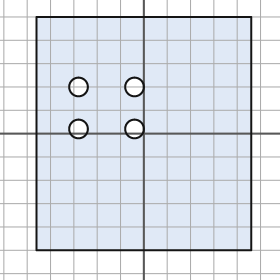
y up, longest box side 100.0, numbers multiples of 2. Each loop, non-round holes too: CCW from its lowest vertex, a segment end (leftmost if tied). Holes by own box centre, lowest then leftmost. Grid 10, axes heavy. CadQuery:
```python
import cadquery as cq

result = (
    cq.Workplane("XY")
    .moveTo(-46.0, -50.0)
    .lineTo(46.0, -50.0)
    .lineTo(46.0, 50.0)
    .lineTo(-46.0, 50.0)
    .close()
    .moveTo(-28.0, 2.0)
    .circle(4.0)
    .moveTo(-4.0, 2.0)
    .circle(4.0)
    .moveTo(-28.0, 20.0)
    .circle(4.0)
    .moveTo(-4.0, 20.0)
    .circle(4.0)
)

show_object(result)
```